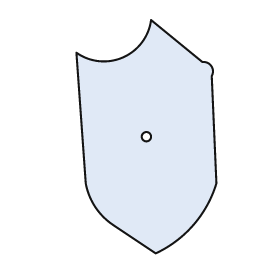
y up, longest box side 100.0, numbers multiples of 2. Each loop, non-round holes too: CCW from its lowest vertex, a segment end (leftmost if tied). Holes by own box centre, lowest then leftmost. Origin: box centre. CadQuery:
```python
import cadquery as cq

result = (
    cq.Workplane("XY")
    .moveTo(4.0, -50.0)
    .threePointArc((20.0, -38.0), (30.0, -20.0))
    .lineTo(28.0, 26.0)
    .threePointArc((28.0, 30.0), (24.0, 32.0))
    .lineTo(2.0, 50.0)
    .threePointArc((-10.0, 34.0), (-30.0, 36.0))
    .lineTo(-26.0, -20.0)
    .threePointArc((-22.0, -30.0), (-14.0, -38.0))
    .close()
    .moveTo(0.0, 0.0)
    .circle(2.0)
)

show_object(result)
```